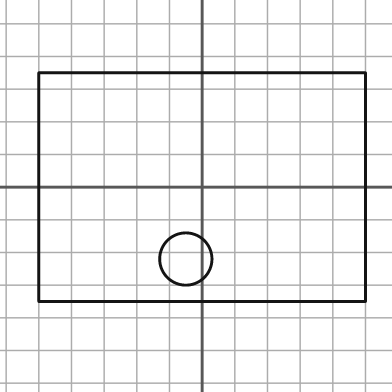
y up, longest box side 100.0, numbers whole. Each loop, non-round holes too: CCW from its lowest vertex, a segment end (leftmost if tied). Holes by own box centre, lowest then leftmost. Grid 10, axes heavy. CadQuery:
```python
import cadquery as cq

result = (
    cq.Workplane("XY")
    .moveTo(-50.0, -35.0)
    .lineTo(50.0, -35.0)
    .lineTo(50.0, 35.0)
    .lineTo(-50.0, 35.0)
    .close()
    .moveTo(-5.0, -22.0)
    .circle(8.0)
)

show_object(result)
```